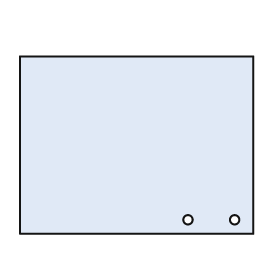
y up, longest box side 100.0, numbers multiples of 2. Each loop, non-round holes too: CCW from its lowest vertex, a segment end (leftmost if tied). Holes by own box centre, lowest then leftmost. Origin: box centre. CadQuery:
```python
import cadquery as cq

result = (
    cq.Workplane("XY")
    .moveTo(-50.0, -38.0)
    .lineTo(50.0, -38.0)
    .lineTo(50.0, 38.0)
    .lineTo(-50.0, 38.0)
    .close()
    .moveTo(22.0, -32.0)
    .circle(2.0)
    .moveTo(42.0, -32.0)
    .circle(2.0)
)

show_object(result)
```